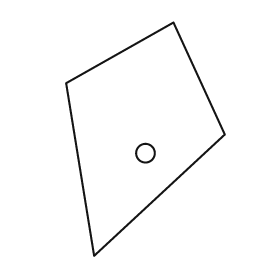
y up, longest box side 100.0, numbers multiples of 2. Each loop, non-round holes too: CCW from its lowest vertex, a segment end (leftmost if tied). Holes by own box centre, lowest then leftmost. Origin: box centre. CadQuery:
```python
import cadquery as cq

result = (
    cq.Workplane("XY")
    .moveTo(-22.0, -50.0)
    .lineTo(34.0, 2.0)
    .lineTo(12.0, 50.0)
    .lineTo(-34.0, 24.0)
    .close()
    .moveTo(0.0, -6.0)
    .circle(4.0)
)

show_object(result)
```